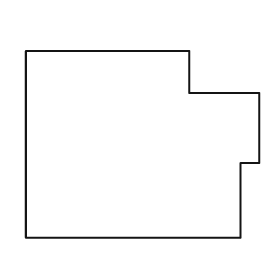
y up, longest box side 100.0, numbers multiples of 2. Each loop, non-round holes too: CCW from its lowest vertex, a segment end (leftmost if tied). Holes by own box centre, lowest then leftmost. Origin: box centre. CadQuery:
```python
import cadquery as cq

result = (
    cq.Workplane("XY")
    .moveTo(-50.0, -40.0)
    .lineTo(42.0, -40.0)
    .lineTo(42.0, -8.0)
    .lineTo(50.0, -8.0)
    .lineTo(50.0, 22.0)
    .lineTo(20.0, 22.0)
    .lineTo(20.0, 40.0)
    .lineTo(-50.0, 40.0)
    .close()
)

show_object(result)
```